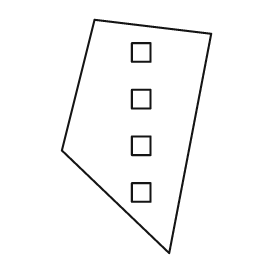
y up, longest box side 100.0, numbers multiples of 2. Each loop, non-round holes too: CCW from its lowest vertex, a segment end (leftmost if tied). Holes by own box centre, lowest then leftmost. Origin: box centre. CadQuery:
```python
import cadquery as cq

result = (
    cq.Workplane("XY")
    .moveTo(14.0, -50.0)
    .lineTo(32.0, 44.0)
    .lineTo(-18.0, 50.0)
    .lineTo(-32.0, -6.0)
    .close()
    .moveTo(-2.0, -28.0)
    .lineTo(6.0, -28.0)
    .lineTo(6.0, -20.0)
    .lineTo(-2.0, -20.0)
    .close()
    .moveTo(-2.0, -8.0)
    .lineTo(6.0, -8.0)
    .lineTo(6.0, 0.0)
    .lineTo(-2.0, 0.0)
    .close()
    .moveTo(-2.0, 12.0)
    .lineTo(6.0, 12.0)
    .lineTo(6.0, 20.0)
    .lineTo(-2.0, 20.0)
    .close()
    .moveTo(-2.0, 32.0)
    .lineTo(6.0, 32.0)
    .lineTo(6.0, 40.0)
    .lineTo(-2.0, 40.0)
    .close()
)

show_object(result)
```